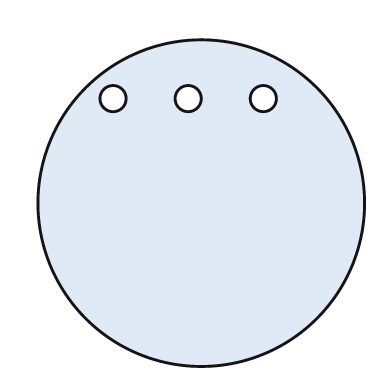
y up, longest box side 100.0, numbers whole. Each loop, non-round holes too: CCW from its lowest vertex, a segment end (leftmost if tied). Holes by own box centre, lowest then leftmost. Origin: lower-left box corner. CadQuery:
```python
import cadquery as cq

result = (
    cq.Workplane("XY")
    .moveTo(50.0, 50.0)
    .circle(50.0)
    .moveTo(23.0, 82.0)
    .circle(4.0)
    .moveTo(46.0, 82.0)
    .circle(4.0)
    .moveTo(69.0, 82.0)
    .circle(4.0)
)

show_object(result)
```